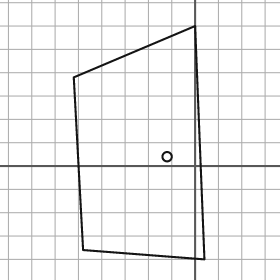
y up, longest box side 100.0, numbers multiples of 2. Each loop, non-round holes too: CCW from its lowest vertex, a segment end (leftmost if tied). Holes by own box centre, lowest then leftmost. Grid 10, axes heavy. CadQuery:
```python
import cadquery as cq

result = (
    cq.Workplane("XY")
    .moveTo(4.0, -40.0)
    .lineTo(0.0, 60.0)
    .lineTo(-52.0, 38.0)
    .lineTo(-48.0, -36.0)
    .close()
    .moveTo(-12.0, 4.0)
    .circle(2.0)
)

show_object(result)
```